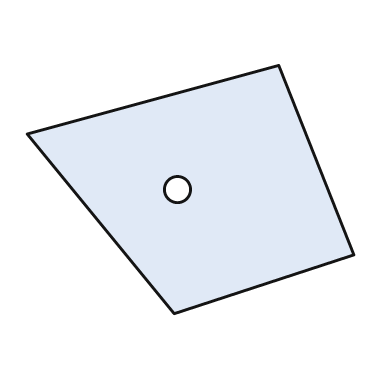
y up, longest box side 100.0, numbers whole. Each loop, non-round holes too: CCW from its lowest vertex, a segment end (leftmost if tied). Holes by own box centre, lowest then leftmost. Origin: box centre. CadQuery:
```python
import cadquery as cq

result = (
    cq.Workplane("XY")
    .moveTo(-5.0, -38.0)
    .lineTo(50.0, -20.0)
    .lineTo(27.0, 38.0)
    .lineTo(-50.0, 17.0)
    .close()
    .moveTo(-4.0, 0.0)
    .circle(4.0)
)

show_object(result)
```